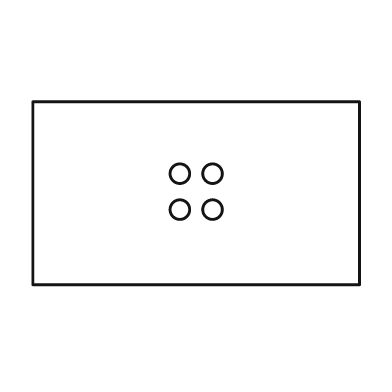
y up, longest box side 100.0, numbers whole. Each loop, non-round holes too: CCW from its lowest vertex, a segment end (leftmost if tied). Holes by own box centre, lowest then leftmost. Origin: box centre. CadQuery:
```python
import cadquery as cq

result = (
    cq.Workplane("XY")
    .moveTo(-50.0, -28.0)
    .lineTo(50.0, -28.0)
    .lineTo(50.0, 28.0)
    .lineTo(-50.0, 28.0)
    .close()
    .moveTo(-5.0, -5.0)
    .circle(3.0)
    .moveTo(5.0, -5.0)
    .circle(3.0)
    .moveTo(-5.0, 6.0)
    .circle(3.0)
    .moveTo(5.0, 6.0)
    .circle(3.0)
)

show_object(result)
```